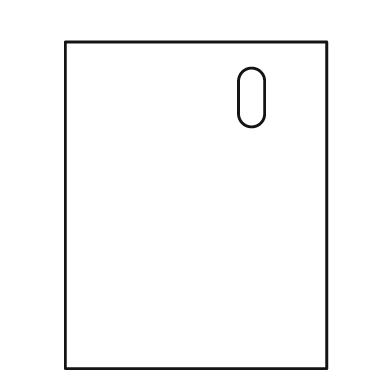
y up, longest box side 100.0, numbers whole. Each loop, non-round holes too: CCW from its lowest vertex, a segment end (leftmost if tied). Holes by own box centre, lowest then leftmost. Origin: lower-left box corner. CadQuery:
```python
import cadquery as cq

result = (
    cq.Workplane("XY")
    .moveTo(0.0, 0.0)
    .lineTo(80.0, 0.0)
    .lineTo(80.0, 100.0)
    .lineTo(0.0, 100.0)
    .close()
    .moveTo(53.0, 78.0)
    .threePointArc((57.0, 74.0), (61.0, 78.0))
    .lineTo(61.0, 88.0)
    .threePointArc((57.0, 92.0), (53.0, 88.0))
    .close()
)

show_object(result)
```